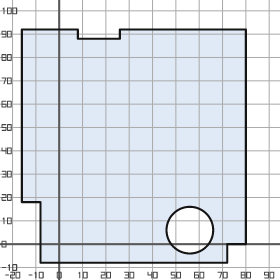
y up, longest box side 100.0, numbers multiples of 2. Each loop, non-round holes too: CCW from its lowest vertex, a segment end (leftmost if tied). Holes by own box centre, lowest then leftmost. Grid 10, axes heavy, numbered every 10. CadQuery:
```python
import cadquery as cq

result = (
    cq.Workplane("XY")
    .moveTo(-8.0, -8.0)
    .lineTo(72.0, -8.0)
    .lineTo(72.0, 0.0)
    .lineTo(80.0, 0.0)
    .lineTo(80.0, 92.0)
    .lineTo(26.0, 92.0)
    .lineTo(26.0, 88.0)
    .lineTo(8.0, 88.0)
    .lineTo(8.0, 92.0)
    .lineTo(-16.0, 92.0)
    .lineTo(-16.0, 18.0)
    .lineTo(-8.0, 18.0)
    .close()
    .moveTo(56.0, 6.0)
    .circle(10.0)
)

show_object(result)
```